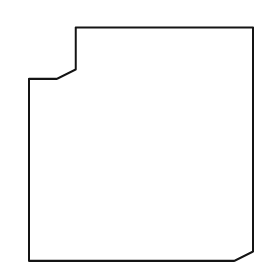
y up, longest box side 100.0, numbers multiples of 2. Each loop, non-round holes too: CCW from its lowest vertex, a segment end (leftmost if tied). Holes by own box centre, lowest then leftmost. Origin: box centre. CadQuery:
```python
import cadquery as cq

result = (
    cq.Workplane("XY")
    .moveTo(-48.0, -50.0)
    .lineTo(40.0, -50.0)
    .lineTo(48.0, -46.0)
    .lineTo(48.0, 50.0)
    .lineTo(-28.0, 50.0)
    .lineTo(-28.0, 32.0)
    .lineTo(-36.0, 28.0)
    .lineTo(-48.0, 28.0)
    .close()
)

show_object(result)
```